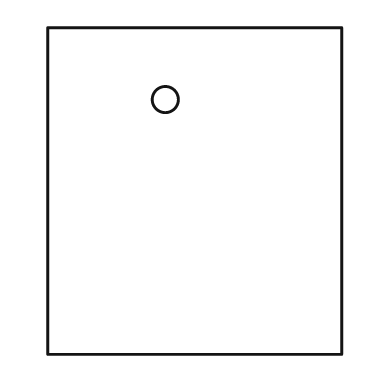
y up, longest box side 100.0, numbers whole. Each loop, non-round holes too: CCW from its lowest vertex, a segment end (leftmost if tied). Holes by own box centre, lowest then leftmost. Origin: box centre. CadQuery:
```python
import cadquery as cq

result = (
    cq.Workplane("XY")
    .moveTo(-45.0, -50.0)
    .lineTo(45.0, -50.0)
    .lineTo(45.0, 50.0)
    .lineTo(-45.0, 50.0)
    .close()
    .moveTo(-9.0, 28.0)
    .circle(4.0)
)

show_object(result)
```